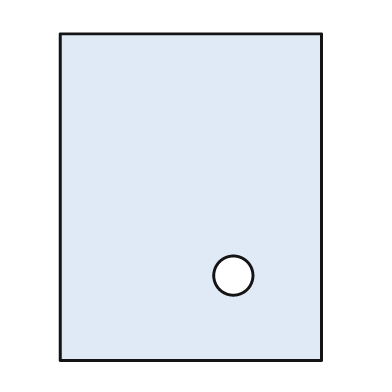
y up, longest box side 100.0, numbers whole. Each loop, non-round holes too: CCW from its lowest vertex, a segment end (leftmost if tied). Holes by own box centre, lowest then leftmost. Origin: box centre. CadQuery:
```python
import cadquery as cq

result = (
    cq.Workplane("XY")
    .moveTo(-40.0, -50.0)
    .lineTo(40.0, -50.0)
    .lineTo(40.0, 50.0)
    .lineTo(-40.0, 50.0)
    .close()
    .moveTo(13.0, -24.0)
    .circle(6.0)
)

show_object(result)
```